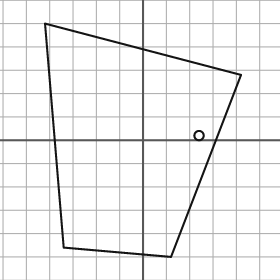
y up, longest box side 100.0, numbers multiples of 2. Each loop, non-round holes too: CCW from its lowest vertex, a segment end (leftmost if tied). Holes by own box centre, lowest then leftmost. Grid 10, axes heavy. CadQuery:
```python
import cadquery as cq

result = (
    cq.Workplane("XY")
    .moveTo(12.0, -50.0)
    .lineTo(42.0, 28.0)
    .lineTo(-42.0, 50.0)
    .lineTo(-34.0, -46.0)
    .close()
    .moveTo(24.0, 2.0)
    .circle(2.0)
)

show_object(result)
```